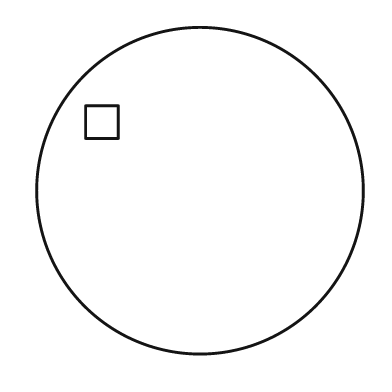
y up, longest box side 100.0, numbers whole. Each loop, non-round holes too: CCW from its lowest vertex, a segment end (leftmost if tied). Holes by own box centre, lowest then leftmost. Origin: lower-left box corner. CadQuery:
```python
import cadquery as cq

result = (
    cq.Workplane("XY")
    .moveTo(50.0, 50.0)
    .circle(50.0)
    .moveTo(15.0, 66.0)
    .lineTo(25.0, 66.0)
    .lineTo(25.0, 76.0)
    .lineTo(15.0, 76.0)
    .close()
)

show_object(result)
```